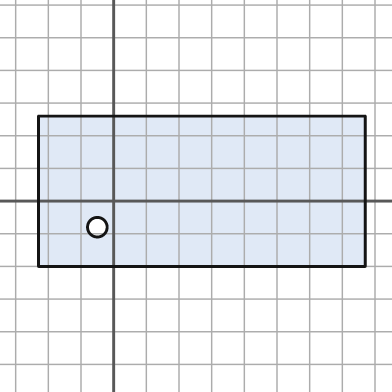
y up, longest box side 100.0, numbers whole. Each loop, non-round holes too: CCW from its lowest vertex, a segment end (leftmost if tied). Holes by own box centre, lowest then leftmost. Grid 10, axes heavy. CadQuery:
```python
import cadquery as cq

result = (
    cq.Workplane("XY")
    .moveTo(-23.0, -20.0)
    .lineTo(77.0, -20.0)
    .lineTo(77.0, 26.0)
    .lineTo(-23.0, 26.0)
    .close()
    .moveTo(-5.0, -8.0)
    .circle(3.0)
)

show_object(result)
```